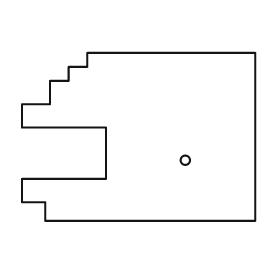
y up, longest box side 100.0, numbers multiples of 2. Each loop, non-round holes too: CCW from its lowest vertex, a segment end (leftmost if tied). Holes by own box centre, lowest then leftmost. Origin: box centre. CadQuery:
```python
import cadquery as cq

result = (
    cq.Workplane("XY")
    .moveTo(-40.0, -36.0)
    .lineTo(50.0, -36.0)
    .lineTo(50.0, 36.0)
    .lineTo(-22.0, 36.0)
    .lineTo(-22.0, 30.0)
    .lineTo(-30.0, 30.0)
    .lineTo(-30.0, 24.0)
    .lineTo(-38.0, 24.0)
    .lineTo(-38.0, 14.0)
    .lineTo(-50.0, 14.0)
    .lineTo(-50.0, 4.0)
    .lineTo(-14.0, 4.0)
    .lineTo(-14.0, -18.0)
    .lineTo(-50.0, -18.0)
    .lineTo(-50.0, -28.0)
    .lineTo(-40.0, -28.0)
    .close()
    .moveTo(20.0, -10.0)
    .circle(2.0)
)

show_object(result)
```